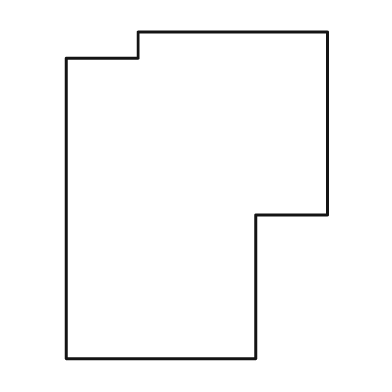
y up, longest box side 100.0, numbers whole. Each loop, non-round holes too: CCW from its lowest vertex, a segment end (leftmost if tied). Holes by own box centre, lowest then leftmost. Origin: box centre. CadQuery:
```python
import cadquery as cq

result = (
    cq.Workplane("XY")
    .moveTo(-40.0, -50.0)
    .lineTo(18.0, -50.0)
    .lineTo(18.0, -6.0)
    .lineTo(40.0, -6.0)
    .lineTo(40.0, 50.0)
    .lineTo(-18.0, 50.0)
    .lineTo(-18.0, 42.0)
    .lineTo(-40.0, 42.0)
    .close()
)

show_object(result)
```